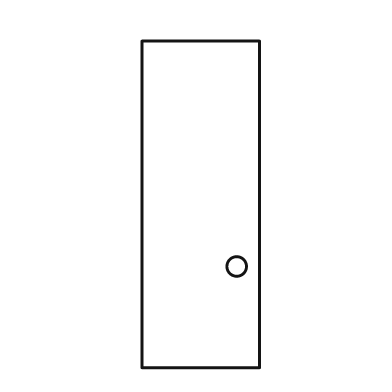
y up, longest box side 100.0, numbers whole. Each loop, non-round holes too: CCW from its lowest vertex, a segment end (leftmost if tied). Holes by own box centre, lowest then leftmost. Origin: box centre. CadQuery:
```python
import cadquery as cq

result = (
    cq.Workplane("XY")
    .moveTo(-18.0, -50.0)
    .lineTo(18.0, -50.0)
    .lineTo(18.0, 50.0)
    .lineTo(-18.0, 50.0)
    .close()
    .moveTo(11.0, -19.0)
    .circle(3.0)
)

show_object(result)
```